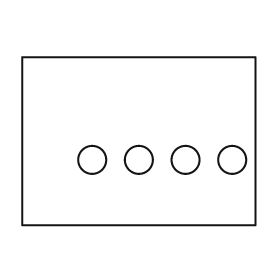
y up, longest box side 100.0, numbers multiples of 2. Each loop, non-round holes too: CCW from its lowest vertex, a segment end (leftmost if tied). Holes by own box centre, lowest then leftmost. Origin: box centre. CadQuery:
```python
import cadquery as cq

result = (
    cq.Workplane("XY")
    .moveTo(-50.0, -36.0)
    .lineTo(50.0, -36.0)
    .lineTo(50.0, 36.0)
    .lineTo(-50.0, 36.0)
    .close()
    .moveTo(-20.0, -8.0)
    .circle(6.0)
    .moveTo(0.0, -8.0)
    .circle(6.0)
    .moveTo(20.0, -8.0)
    .circle(6.0)
    .moveTo(40.0, -8.0)
    .circle(6.0)
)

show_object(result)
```